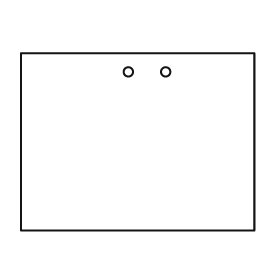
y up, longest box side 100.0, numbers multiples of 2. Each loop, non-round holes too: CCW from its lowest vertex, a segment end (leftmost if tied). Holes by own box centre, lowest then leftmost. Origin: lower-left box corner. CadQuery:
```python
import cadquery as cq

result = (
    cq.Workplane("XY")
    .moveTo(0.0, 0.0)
    .lineTo(100.0, 0.0)
    .lineTo(100.0, 76.0)
    .lineTo(0.0, 76.0)
    .close()
    .moveTo(46.0, 68.0)
    .circle(2.0)
    .moveTo(62.0, 68.0)
    .circle(2.0)
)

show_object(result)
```